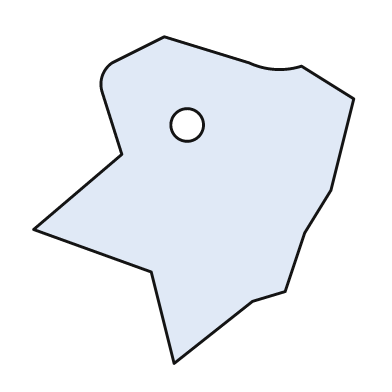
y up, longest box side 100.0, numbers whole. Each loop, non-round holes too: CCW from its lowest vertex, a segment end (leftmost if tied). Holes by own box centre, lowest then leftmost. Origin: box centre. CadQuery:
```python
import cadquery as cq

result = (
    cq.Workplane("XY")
    .moveTo(-6.0, -50.0)
    .lineTo(18.0, -31.0)
    .lineTo(28.0, -28.0)
    .lineTo(34.0, -10.0)
    .lineTo(42.0, 3.0)
    .lineTo(49.0, 31.0)
    .lineTo(33.0, 41.0)
    .threePointArc((25.0, 40.0), (17.0, 42.0))
    .lineTo(-9.0, 50.0)
    .lineTo(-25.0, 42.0)
    .threePointArc((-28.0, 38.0), (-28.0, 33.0))
    .lineTo(-22.0, 14.0)
    .lineTo(-49.0, -9.0)
    .lineTo(-13.0, -22.0)
    .close()
    .moveTo(-2.0, 23.0)
    .circle(5.0)
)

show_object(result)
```